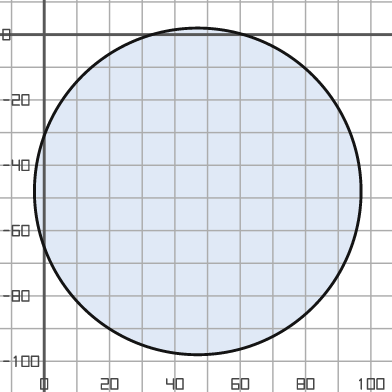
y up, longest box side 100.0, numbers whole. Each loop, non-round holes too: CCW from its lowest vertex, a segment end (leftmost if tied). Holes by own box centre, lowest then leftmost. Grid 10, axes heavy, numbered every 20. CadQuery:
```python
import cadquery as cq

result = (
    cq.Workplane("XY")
    .moveTo(47.0, -48.0)
    .circle(50.0)
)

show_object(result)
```